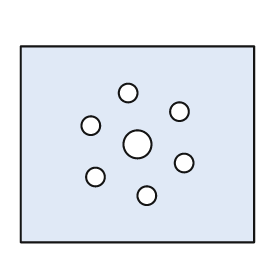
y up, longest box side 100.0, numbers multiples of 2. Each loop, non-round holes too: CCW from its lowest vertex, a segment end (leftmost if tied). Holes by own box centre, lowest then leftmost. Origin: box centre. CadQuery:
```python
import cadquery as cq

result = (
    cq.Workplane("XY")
    .moveTo(-50.0, -42.0)
    .lineTo(50.0, -42.0)
    .lineTo(50.0, 42.0)
    .lineTo(-50.0, 42.0)
    .close()
    .moveTo(4.0, -22.0)
    .circle(4.0)
    .moveTo(-18.0, -14.0)
    .circle(4.0)
    .moveTo(20.0, -8.0)
    .circle(4.0)
    .moveTo(0.0, 0.0)
    .circle(6.0)
    .moveTo(-20.0, 8.0)
    .circle(4.0)
    .moveTo(18.0, 14.0)
    .circle(4.0)
    .moveTo(-4.0, 22.0)
    .circle(4.0)
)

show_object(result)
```